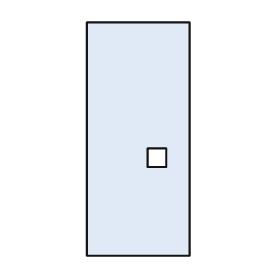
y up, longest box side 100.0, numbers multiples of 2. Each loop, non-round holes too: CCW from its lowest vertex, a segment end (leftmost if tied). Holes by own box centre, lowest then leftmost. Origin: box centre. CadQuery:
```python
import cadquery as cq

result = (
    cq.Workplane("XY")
    .moveTo(-22.0, -50.0)
    .lineTo(22.0, -50.0)
    .lineTo(22.0, 50.0)
    .lineTo(-22.0, 50.0)
    .close()
    .moveTo(4.0, -12.0)
    .lineTo(12.0, -12.0)
    .lineTo(12.0, -4.0)
    .lineTo(4.0, -4.0)
    .close()
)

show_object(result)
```